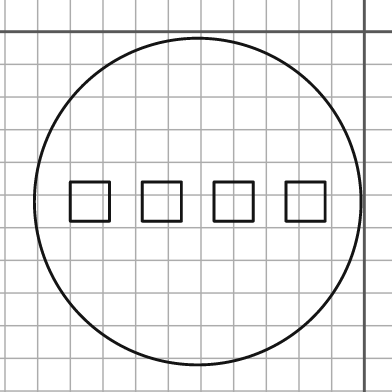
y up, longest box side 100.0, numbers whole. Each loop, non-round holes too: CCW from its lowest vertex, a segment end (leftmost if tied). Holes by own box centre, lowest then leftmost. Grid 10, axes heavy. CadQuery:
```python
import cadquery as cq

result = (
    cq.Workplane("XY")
    .moveTo(-51.0, -52.0)
    .circle(50.0)
    .moveTo(-90.0, -58.0)
    .lineTo(-78.0, -58.0)
    .lineTo(-78.0, -46.0)
    .lineTo(-90.0, -46.0)
    .close()
    .moveTo(-68.0, -58.0)
    .lineTo(-56.0, -58.0)
    .lineTo(-56.0, -46.0)
    .lineTo(-68.0, -46.0)
    .close()
    .moveTo(-46.0, -58.0)
    .lineTo(-34.0, -58.0)
    .lineTo(-34.0, -46.0)
    .lineTo(-46.0, -46.0)
    .close()
    .moveTo(-24.0, -58.0)
    .lineTo(-12.0, -58.0)
    .lineTo(-12.0, -46.0)
    .lineTo(-24.0, -46.0)
    .close()
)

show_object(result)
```